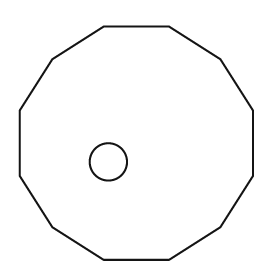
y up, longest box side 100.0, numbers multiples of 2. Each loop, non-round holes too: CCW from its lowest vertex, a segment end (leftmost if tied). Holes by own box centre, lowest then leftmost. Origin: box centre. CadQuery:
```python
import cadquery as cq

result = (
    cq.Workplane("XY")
    .moveTo(-14.0, -50.0)
    .lineTo(14.0, -50.0)
    .lineTo(36.0, -36.0)
    .lineTo(50.0, -14.0)
    .lineTo(50.0, 14.0)
    .lineTo(36.0, 36.0)
    .lineTo(14.0, 50.0)
    .lineTo(-14.0, 50.0)
    .lineTo(-36.0, 36.0)
    .lineTo(-50.0, 14.0)
    .lineTo(-50.0, -14.0)
    .lineTo(-36.0, -36.0)
    .close()
    .moveTo(-12.0, -8.0)
    .circle(8.0)
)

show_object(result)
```